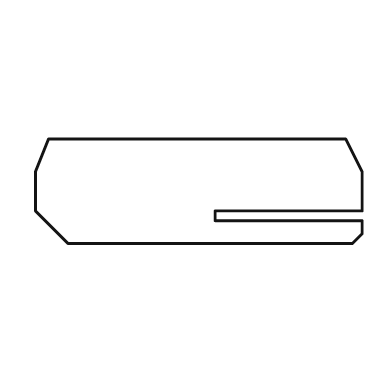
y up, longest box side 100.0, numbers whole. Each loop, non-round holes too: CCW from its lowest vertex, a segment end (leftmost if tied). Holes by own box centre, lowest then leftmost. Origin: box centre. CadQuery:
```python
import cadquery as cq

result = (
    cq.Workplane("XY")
    .moveTo(-40.0, -16.0)
    .lineTo(47.0, -16.0)
    .lineTo(50.0, -13.0)
    .lineTo(50.0, -9.0)
    .lineTo(5.0, -9.0)
    .lineTo(5.0, -6.0)
    .lineTo(50.0, -6.0)
    .lineTo(50.0, 6.0)
    .lineTo(45.0, 16.0)
    .lineTo(-46.0, 16.0)
    .lineTo(-50.0, 6.0)
    .lineTo(-50.0, -6.0)
    .close()
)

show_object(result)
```